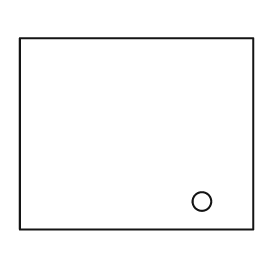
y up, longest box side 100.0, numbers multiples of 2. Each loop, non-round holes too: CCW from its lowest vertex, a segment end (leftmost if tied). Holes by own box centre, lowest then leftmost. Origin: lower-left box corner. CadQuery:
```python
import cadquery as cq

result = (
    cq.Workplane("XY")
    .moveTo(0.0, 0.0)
    .lineTo(100.0, 0.0)
    .lineTo(100.0, 82.0)
    .lineTo(0.0, 82.0)
    .close()
    .moveTo(78.0, 12.0)
    .circle(4.0)
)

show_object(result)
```